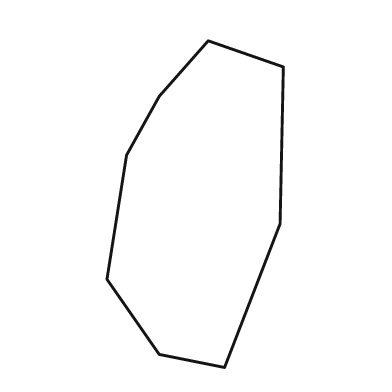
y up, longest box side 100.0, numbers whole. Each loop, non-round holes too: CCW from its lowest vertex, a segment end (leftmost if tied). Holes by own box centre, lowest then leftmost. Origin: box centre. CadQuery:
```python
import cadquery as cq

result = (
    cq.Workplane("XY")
    .moveTo(9.0, -50.0)
    .lineTo(26.0, -6.0)
    .lineTo(27.0, 42.0)
    .lineTo(4.0, 50.0)
    .lineTo(-11.0, 33.0)
    .lineTo(-21.0, 15.0)
    .lineTo(-27.0, -23.0)
    .lineTo(-11.0, -46.0)
    .close()
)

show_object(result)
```